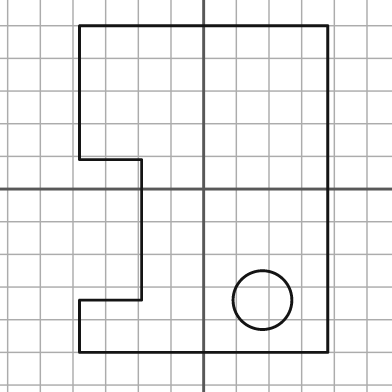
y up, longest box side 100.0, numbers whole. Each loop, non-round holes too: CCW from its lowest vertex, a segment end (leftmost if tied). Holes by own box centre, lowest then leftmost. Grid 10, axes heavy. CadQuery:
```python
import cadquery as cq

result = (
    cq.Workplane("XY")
    .moveTo(-38.0, -50.0)
    .lineTo(38.0, -50.0)
    .lineTo(38.0, 50.0)
    .lineTo(-38.0, 50.0)
    .lineTo(-38.0, 9.0)
    .lineTo(-19.0, 9.0)
    .lineTo(-19.0, -34.0)
    .lineTo(-38.0, -34.0)
    .close()
    .moveTo(18.0, -34.0)
    .circle(9.0)
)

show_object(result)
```